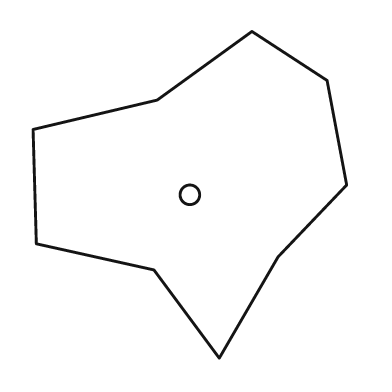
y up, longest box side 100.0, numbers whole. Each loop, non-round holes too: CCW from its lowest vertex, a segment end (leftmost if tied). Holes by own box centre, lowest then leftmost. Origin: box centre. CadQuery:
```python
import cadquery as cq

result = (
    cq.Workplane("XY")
    .moveTo(9.0, -50.0)
    .lineTo(27.0, -19.0)
    .lineTo(48.0, 3.0)
    .lineTo(42.0, 35.0)
    .lineTo(19.0, 50.0)
    .lineTo(-10.0, 29.0)
    .lineTo(-48.0, 20.0)
    .lineTo(-47.0, -15.0)
    .lineTo(-11.0, -23.0)
    .close()
    .moveTo(0.0, 0.0)
    .circle(3.0)
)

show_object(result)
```